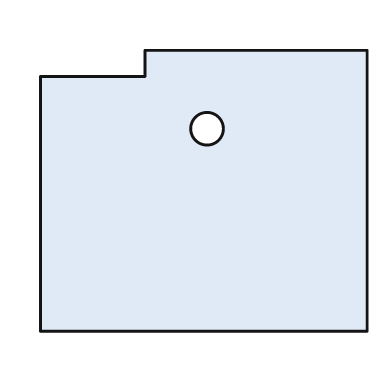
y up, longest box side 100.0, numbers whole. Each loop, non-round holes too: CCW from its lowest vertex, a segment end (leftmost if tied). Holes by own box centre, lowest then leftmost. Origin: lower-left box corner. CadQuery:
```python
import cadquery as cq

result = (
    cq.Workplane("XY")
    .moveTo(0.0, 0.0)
    .lineTo(100.0, 0.0)
    .lineTo(100.0, 86.0)
    .lineTo(32.0, 86.0)
    .lineTo(32.0, 78.0)
    .lineTo(0.0, 78.0)
    .close()
    .moveTo(51.0, 62.0)
    .circle(5.0)
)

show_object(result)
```